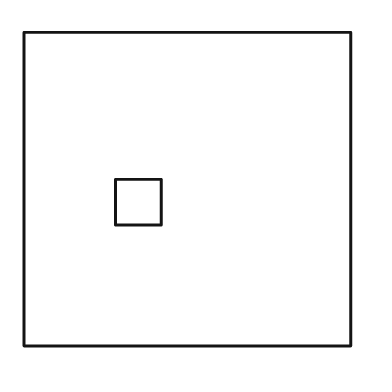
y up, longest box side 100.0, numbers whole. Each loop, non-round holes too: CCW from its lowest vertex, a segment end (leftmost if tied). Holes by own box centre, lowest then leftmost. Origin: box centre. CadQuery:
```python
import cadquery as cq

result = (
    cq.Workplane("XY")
    .moveTo(-50.0, -48.0)
    .lineTo(50.0, -48.0)
    .lineTo(50.0, 48.0)
    .lineTo(-50.0, 48.0)
    .close()
    .moveTo(-22.0, -11.0)
    .lineTo(-8.0, -11.0)
    .lineTo(-8.0, 3.0)
    .lineTo(-22.0, 3.0)
    .close()
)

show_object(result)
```